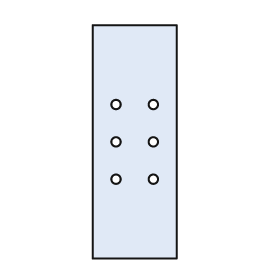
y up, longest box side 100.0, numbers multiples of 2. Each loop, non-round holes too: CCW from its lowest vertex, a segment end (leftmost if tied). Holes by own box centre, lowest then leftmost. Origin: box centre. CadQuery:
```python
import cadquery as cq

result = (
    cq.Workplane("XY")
    .moveTo(-18.0, -50.0)
    .lineTo(18.0, -50.0)
    .lineTo(18.0, 50.0)
    .lineTo(-18.0, 50.0)
    .close()
    .moveTo(-8.0, -16.0)
    .circle(2.0)
    .moveTo(8.0, -16.0)
    .circle(2.0)
    .moveTo(-8.0, 0.0)
    .circle(2.0)
    .moveTo(8.0, 0.0)
    .circle(2.0)
    .moveTo(-8.0, 16.0)
    .circle(2.0)
    .moveTo(8.0, 16.0)
    .circle(2.0)
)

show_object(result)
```